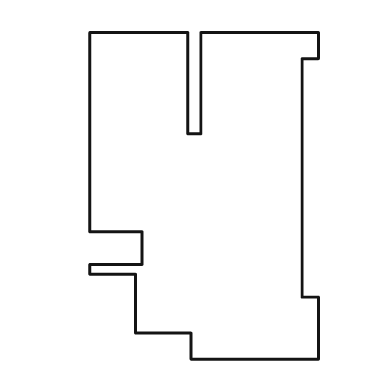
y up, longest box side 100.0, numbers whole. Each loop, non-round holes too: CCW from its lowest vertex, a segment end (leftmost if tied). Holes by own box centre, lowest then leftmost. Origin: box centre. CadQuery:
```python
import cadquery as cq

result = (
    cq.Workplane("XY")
    .moveTo(-4.0, -50.0)
    .lineTo(35.0, -50.0)
    .lineTo(35.0, -31.0)
    .lineTo(30.0, -31.0)
    .lineTo(30.0, 42.0)
    .lineTo(35.0, 42.0)
    .lineTo(35.0, 50.0)
    .lineTo(-1.0, 50.0)
    .lineTo(-1.0, 19.0)
    .lineTo(-5.0, 19.0)
    .lineTo(-5.0, 50.0)
    .lineTo(-35.0, 50.0)
    .lineTo(-35.0, -11.0)
    .lineTo(-19.0, -11.0)
    .lineTo(-19.0, -21.0)
    .lineTo(-35.0, -21.0)
    .lineTo(-35.0, -24.0)
    .lineTo(-21.0, -24.0)
    .lineTo(-21.0, -42.0)
    .lineTo(-4.0, -42.0)
    .close()
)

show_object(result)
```